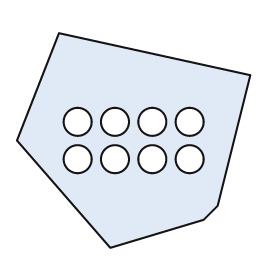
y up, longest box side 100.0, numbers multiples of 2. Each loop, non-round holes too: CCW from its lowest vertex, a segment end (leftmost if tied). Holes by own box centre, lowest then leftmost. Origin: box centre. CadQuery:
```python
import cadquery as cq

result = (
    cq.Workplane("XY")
    .moveTo(-10.0, -46.0)
    .lineTo(30.0, -34.0)
    .lineTo(36.0, -28.0)
    .lineTo(50.0, 28.0)
    .lineTo(-32.0, 46.0)
    .lineTo(-50.0, 0.0)
    .close()
    .moveTo(-24.0, -8.0)
    .circle(6.0)
    .moveTo(-8.0, -8.0)
    .circle(6.0)
    .moveTo(8.0, -8.0)
    .circle(6.0)
    .moveTo(24.0, -8.0)
    .circle(6.0)
    .moveTo(-24.0, 8.0)
    .circle(6.0)
    .moveTo(-8.0, 8.0)
    .circle(6.0)
    .moveTo(8.0, 8.0)
    .circle(6.0)
    .moveTo(24.0, 8.0)
    .circle(6.0)
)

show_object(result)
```